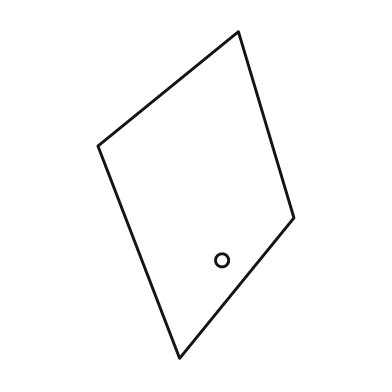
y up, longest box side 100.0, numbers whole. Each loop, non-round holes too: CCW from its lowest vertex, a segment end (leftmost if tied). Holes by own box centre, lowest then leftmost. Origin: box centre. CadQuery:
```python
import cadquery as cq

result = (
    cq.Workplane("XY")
    .moveTo(-5.0, -50.0)
    .lineTo(30.0, -7.0)
    .lineTo(13.0, 50.0)
    .lineTo(-30.0, 15.0)
    .close()
    .moveTo(8.0, -20.0)
    .circle(2.0)
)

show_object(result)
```